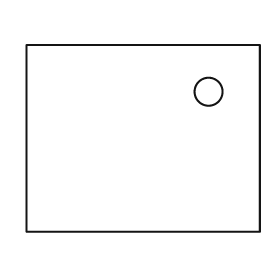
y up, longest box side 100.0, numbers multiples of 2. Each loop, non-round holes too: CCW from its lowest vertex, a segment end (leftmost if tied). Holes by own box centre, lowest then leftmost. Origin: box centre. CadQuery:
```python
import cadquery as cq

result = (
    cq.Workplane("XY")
    .moveTo(-50.0, -40.0)
    .lineTo(50.0, -40.0)
    .lineTo(50.0, 40.0)
    .lineTo(-50.0, 40.0)
    .close()
    .moveTo(28.0, 20.0)
    .circle(6.0)
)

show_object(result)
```